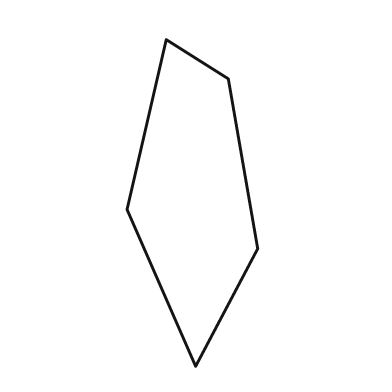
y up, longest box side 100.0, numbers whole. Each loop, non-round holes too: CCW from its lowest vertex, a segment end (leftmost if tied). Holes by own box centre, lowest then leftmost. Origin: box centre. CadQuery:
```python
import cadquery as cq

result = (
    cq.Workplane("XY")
    .moveTo(1.0, -50.0)
    .lineTo(20.0, -14.0)
    .lineTo(11.0, 38.0)
    .lineTo(-8.0, 50.0)
    .lineTo(-20.0, -2.0)
    .close()
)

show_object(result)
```